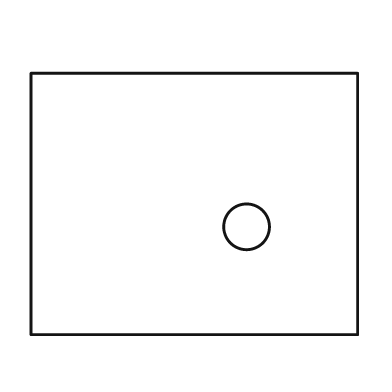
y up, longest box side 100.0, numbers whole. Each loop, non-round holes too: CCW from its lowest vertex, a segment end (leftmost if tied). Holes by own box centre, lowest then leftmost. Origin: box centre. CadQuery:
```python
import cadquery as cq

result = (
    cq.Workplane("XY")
    .moveTo(-50.0, -40.0)
    .lineTo(50.0, -40.0)
    .lineTo(50.0, 40.0)
    .lineTo(-50.0, 40.0)
    .close()
    .moveTo(16.0, -7.0)
    .circle(7.0)
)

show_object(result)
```